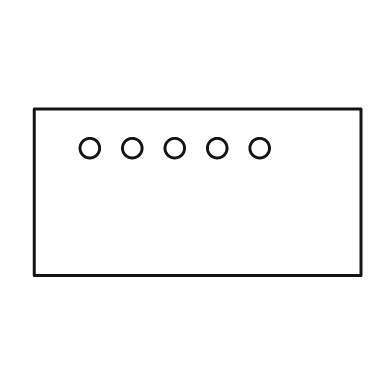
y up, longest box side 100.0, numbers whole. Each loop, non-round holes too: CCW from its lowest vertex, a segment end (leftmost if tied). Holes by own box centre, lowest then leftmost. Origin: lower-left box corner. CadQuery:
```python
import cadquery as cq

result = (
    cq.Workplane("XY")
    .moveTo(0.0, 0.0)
    .lineTo(100.0, 0.0)
    .lineTo(100.0, 51.0)
    .lineTo(0.0, 51.0)
    .close()
    .moveTo(17.0, 39.0)
    .circle(3.0)
    .moveTo(30.0, 39.0)
    .circle(3.0)
    .moveTo(43.0, 39.0)
    .circle(3.0)
    .moveTo(56.0, 39.0)
    .circle(3.0)
    .moveTo(69.0, 39.0)
    .circle(3.0)
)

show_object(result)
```